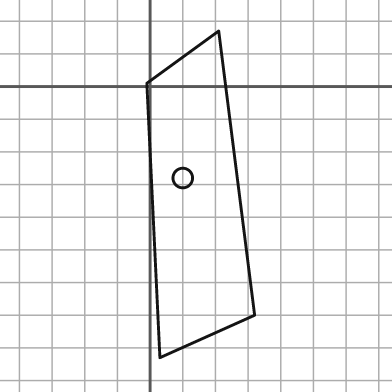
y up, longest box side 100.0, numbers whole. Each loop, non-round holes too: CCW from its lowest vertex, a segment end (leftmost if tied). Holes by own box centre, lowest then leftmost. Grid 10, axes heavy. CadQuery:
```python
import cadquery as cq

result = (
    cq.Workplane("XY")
    .moveTo(3.0, -83.0)
    .lineTo(32.0, -70.0)
    .lineTo(21.0, 17.0)
    .lineTo(-1.0, 1.0)
    .close()
    .moveTo(10.0, -28.0)
    .circle(3.0)
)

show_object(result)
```